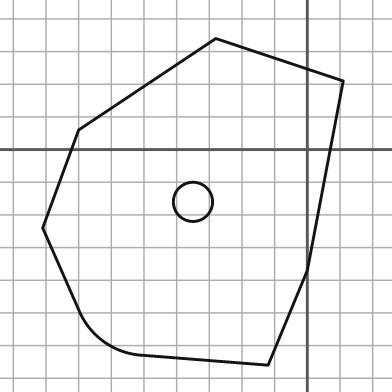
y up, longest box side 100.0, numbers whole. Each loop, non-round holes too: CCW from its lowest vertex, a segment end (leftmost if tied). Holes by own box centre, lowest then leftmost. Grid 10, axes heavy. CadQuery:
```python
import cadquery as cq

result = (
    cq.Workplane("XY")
    .moveTo(-12.0, -66.0)
    .lineTo(0.0, -37.0)
    .lineTo(11.0, 21.0)
    .lineTo(-28.0, 34.0)
    .lineTo(-70.0, 6.0)
    .lineTo(-81.0, -24.0)
    .lineTo(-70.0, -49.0)
    .threePointArc((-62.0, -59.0), (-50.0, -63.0))
    .close()
    .moveTo(-35.0, -16.0)
    .circle(6.0)
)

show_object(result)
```